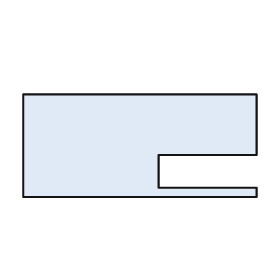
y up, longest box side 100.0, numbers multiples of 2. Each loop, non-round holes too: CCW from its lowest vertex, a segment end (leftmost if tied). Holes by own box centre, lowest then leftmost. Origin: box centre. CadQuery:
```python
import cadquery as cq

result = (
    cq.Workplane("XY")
    .moveTo(-50.0, -22.0)
    .lineTo(50.0, -22.0)
    .lineTo(50.0, -18.0)
    .lineTo(8.0, -18.0)
    .lineTo(8.0, -4.0)
    .lineTo(50.0, -4.0)
    .lineTo(50.0, 22.0)
    .lineTo(-50.0, 22.0)
    .close()
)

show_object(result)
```